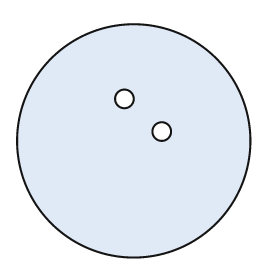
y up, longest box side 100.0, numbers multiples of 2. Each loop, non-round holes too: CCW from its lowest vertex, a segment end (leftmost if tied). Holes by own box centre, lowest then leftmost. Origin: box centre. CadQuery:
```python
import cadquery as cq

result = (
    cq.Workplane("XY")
    .moveTo(0.0, 0.0)
    .circle(50.0)
    .moveTo(12.0, 4.0)
    .circle(4.0)
    .moveTo(-4.0, 18.0)
    .circle(4.0)
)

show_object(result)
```